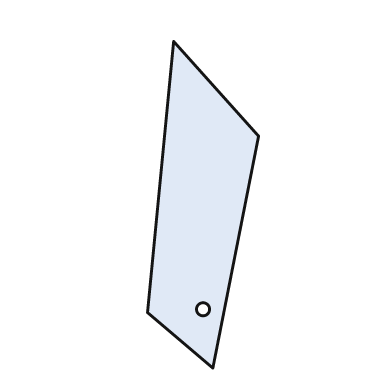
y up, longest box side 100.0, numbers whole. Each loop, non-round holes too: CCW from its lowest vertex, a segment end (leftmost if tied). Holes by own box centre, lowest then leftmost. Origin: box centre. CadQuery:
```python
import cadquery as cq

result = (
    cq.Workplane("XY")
    .moveTo(3.0, -50.0)
    .lineTo(17.0, 21.0)
    .lineTo(-9.0, 50.0)
    .lineTo(-17.0, -33.0)
    .close()
    .moveTo(0.0, -32.0)
    .circle(2.0)
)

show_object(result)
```